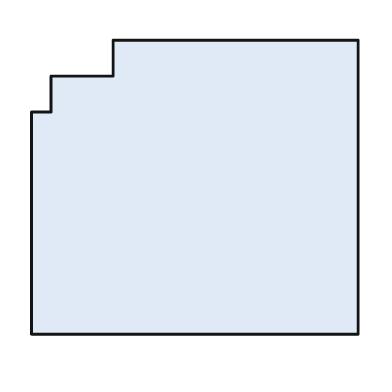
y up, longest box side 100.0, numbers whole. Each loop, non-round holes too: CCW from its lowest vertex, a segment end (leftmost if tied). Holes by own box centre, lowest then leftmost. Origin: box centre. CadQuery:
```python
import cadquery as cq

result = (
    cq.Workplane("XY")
    .moveTo(-50.0, -45.0)
    .lineTo(50.0, -45.0)
    .lineTo(50.0, 45.0)
    .lineTo(-25.0, 45.0)
    .lineTo(-25.0, 34.0)
    .lineTo(-44.0, 34.0)
    .lineTo(-44.0, 23.0)
    .lineTo(-50.0, 23.0)
    .close()
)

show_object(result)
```